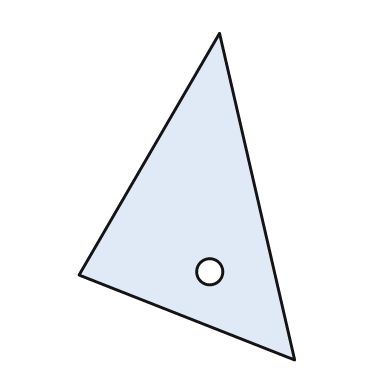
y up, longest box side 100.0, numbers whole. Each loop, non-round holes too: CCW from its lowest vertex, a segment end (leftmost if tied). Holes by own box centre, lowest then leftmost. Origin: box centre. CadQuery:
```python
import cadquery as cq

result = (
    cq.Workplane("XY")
    .moveTo(33.0, -50.0)
    .lineTo(10.0, 50.0)
    .lineTo(-33.0, -24.0)
    .close()
    .moveTo(7.0, -23.0)
    .circle(4.0)
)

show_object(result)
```